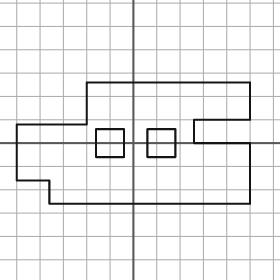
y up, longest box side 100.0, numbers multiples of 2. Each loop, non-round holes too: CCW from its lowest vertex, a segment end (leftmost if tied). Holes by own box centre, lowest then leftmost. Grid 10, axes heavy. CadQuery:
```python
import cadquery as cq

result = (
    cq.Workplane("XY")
    .moveTo(-36.0, -26.0)
    .lineTo(50.0, -26.0)
    .lineTo(50.0, 0.0)
    .lineTo(26.0, 0.0)
    .lineTo(26.0, 10.0)
    .lineTo(50.0, 10.0)
    .lineTo(50.0, 26.0)
    .lineTo(-20.0, 26.0)
    .lineTo(-20.0, 8.0)
    .lineTo(-50.0, 8.0)
    .lineTo(-50.0, -16.0)
    .lineTo(-36.0, -16.0)
    .close()
    .moveTo(-16.0, -6.0)
    .lineTo(-4.0, -6.0)
    .lineTo(-4.0, 6.0)
    .lineTo(-16.0, 6.0)
    .close()
    .moveTo(6.0, -6.0)
    .lineTo(18.0, -6.0)
    .lineTo(18.0, 6.0)
    .lineTo(6.0, 6.0)
    .close()
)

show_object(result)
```